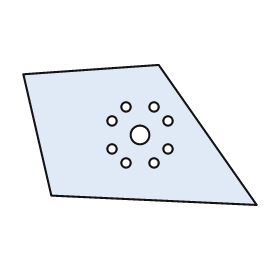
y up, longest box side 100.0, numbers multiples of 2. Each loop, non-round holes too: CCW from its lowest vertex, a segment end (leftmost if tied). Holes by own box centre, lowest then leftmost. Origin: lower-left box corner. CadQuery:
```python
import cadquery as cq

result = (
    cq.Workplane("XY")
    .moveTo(100.0, 0.0)
    .lineTo(58.0, 60.0)
    .lineTo(0.0, 56.0)
    .lineTo(12.0, 4.0)
    .close()
    .moveTo(44.0, 18.0)
    .circle(2.0)
    .moveTo(56.0, 18.0)
    .circle(2.0)
    .moveTo(38.0, 24.0)
    .circle(2.0)
    .moveTo(62.0, 24.0)
    .circle(2.0)
    .moveTo(50.0, 30.0)
    .circle(4.0)
    .moveTo(38.0, 36.0)
    .circle(2.0)
    .moveTo(62.0, 36.0)
    .circle(2.0)
    .moveTo(44.0, 42.0)
    .circle(2.0)
    .moveTo(56.0, 42.0)
    .circle(2.0)
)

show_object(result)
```